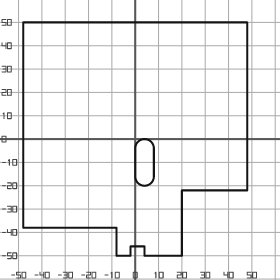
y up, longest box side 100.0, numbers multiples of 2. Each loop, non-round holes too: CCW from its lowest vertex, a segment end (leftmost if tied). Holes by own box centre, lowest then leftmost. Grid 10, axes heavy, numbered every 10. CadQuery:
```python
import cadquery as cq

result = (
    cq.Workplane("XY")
    .moveTo(-8.0, -50.0)
    .lineTo(-2.0, -50.0)
    .lineTo(-2.0, -46.0)
    .lineTo(4.0, -46.0)
    .lineTo(4.0, -50.0)
    .lineTo(20.0, -50.0)
    .lineTo(20.0, -22.0)
    .lineTo(48.0, -22.0)
    .lineTo(48.0, 50.0)
    .lineTo(-48.0, 50.0)
    .lineTo(-48.0, -38.0)
    .lineTo(-8.0, -38.0)
    .close()
    .moveTo(0.0, -16.0)
    .threePointArc((4.0, -20.0), (8.0, -16.0))
    .lineTo(8.0, -4.0)
    .threePointArc((4.0, 0.0), (0.0, -4.0))
    .close()
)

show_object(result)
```